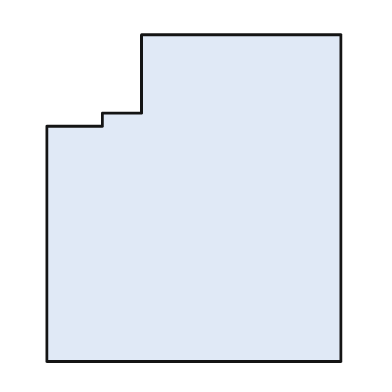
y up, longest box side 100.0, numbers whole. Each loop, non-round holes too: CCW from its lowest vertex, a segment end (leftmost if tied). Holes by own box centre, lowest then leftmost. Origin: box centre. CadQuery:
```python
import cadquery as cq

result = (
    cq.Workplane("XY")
    .moveTo(-45.0, -50.0)
    .lineTo(45.0, -50.0)
    .lineTo(45.0, 50.0)
    .lineTo(-16.0, 50.0)
    .lineTo(-16.0, 26.0)
    .lineTo(-28.0, 26.0)
    .lineTo(-28.0, 22.0)
    .lineTo(-45.0, 22.0)
    .close()
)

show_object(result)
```